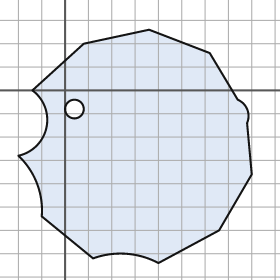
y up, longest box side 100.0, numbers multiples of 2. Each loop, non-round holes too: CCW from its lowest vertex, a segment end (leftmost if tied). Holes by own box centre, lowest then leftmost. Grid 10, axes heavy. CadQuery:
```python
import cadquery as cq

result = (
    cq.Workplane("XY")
    .moveTo(40.0, -74.0)
    .lineTo(66.0, -60.0)
    .lineTo(80.0, -36.0)
    .lineTo(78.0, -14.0)
    .threePointArc((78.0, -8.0), (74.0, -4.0))
    .lineTo(62.0, 16.0)
    .lineTo(36.0, 26.0)
    .lineTo(8.0, 20.0)
    .lineTo(-14.0, 0.0)
    .threePointArc((-8.0, -16.0), (-20.0, -28.0))
    .threePointArc((-12.0, -40.0), (-10.0, -54.0))
    .lineTo(12.0, -72.0)
    .threePointArc((26.0, -70.0), (40.0, -74.0))
    .close()
    .moveTo(4.0, -8.0)
    .circle(4.0)
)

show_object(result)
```